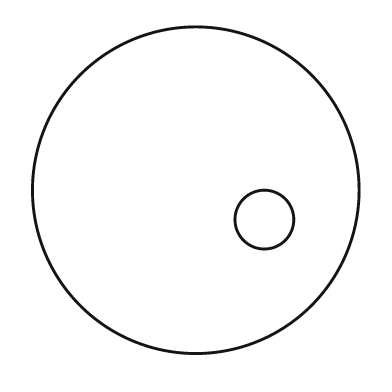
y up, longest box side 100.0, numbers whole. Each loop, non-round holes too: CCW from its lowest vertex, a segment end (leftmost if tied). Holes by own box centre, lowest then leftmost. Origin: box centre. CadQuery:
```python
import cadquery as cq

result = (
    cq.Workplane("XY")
    .moveTo(0.0, 0.0)
    .circle(50.0)
    .moveTo(21.0, -9.0)
    .circle(9.0)
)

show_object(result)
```